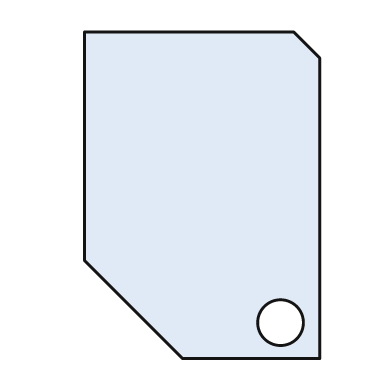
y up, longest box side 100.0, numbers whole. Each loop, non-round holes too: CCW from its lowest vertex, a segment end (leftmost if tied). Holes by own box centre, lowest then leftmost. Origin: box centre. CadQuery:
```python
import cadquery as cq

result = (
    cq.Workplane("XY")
    .moveTo(-6.0, -50.0)
    .lineTo(36.0, -50.0)
    .lineTo(36.0, 42.0)
    .lineTo(28.0, 50.0)
    .lineTo(-36.0, 50.0)
    .lineTo(-36.0, -20.0)
    .close()
    .moveTo(24.0, -39.0)
    .circle(7.0)
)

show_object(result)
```